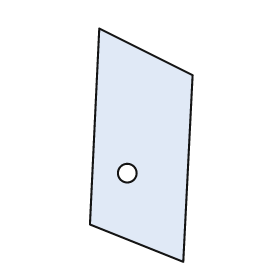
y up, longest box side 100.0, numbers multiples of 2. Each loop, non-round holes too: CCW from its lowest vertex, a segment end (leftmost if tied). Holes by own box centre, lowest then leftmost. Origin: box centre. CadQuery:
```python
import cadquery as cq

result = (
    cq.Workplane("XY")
    .moveTo(18.0, -50.0)
    .lineTo(22.0, 30.0)
    .lineTo(-18.0, 50.0)
    .lineTo(-22.0, -34.0)
    .close()
    .moveTo(-6.0, -12.0)
    .circle(4.0)
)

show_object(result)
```